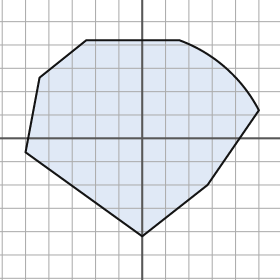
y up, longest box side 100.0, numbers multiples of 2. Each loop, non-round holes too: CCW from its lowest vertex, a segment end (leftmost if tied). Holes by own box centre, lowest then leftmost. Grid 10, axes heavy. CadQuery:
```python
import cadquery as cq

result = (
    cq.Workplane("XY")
    .moveTo(0.0, -42.0)
    .lineTo(28.0, -20.0)
    .lineTo(50.0, 12.0)
    .threePointArc((36.0, 30.0), (16.0, 42.0))
    .lineTo(-24.0, 42.0)
    .lineTo(-44.0, 26.0)
    .lineTo(-50.0, -6.0)
    .close()
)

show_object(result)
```